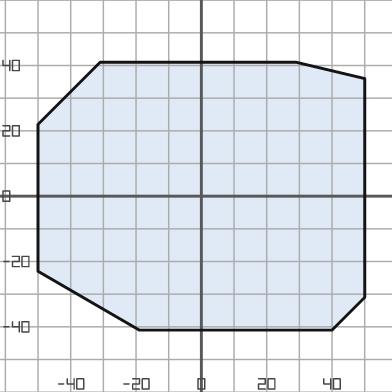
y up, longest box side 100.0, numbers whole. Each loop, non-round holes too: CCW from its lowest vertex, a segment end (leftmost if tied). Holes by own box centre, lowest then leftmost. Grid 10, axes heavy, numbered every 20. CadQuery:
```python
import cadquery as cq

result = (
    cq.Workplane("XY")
    .moveTo(-19.0, -41.0)
    .lineTo(40.0, -41.0)
    .lineTo(50.0, -31.0)
    .lineTo(50.0, 36.0)
    .lineTo(29.0, 41.0)
    .lineTo(-31.0, 41.0)
    .lineTo(-50.0, 22.0)
    .lineTo(-50.0, -23.0)
    .close()
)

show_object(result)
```